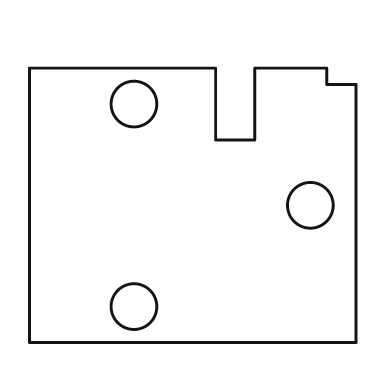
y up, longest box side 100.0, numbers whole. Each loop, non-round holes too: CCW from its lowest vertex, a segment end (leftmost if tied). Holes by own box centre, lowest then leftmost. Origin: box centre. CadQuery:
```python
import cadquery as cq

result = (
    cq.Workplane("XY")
    .moveTo(-50.0, -42.0)
    .lineTo(50.0, -42.0)
    .lineTo(50.0, 37.0)
    .lineTo(41.0, 37.0)
    .lineTo(41.0, 42.0)
    .lineTo(19.0, 42.0)
    .lineTo(19.0, 20.0)
    .lineTo(7.0, 20.0)
    .lineTo(7.0, 42.0)
    .lineTo(-50.0, 42.0)
    .close()
    .moveTo(-18.0, -31.0)
    .circle(7.0)
    .moveTo(36.0, 0.0)
    .circle(7.0)
    .moveTo(-18.0, 31.0)
    .circle(7.0)
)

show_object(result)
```